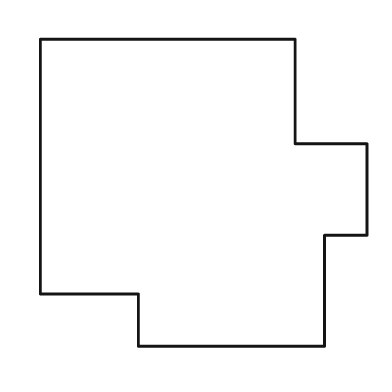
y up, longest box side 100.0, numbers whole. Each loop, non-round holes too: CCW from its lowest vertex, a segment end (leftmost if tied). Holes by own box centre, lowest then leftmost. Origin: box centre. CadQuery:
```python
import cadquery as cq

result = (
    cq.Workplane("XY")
    .moveTo(-20.0, -47.0)
    .lineTo(37.0, -47.0)
    .lineTo(37.0, -13.0)
    .lineTo(50.0, -13.0)
    .lineTo(50.0, 15.0)
    .lineTo(28.0, 15.0)
    .lineTo(28.0, 47.0)
    .lineTo(-50.0, 47.0)
    .lineTo(-50.0, -31.0)
    .lineTo(-20.0, -31.0)
    .close()
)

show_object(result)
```